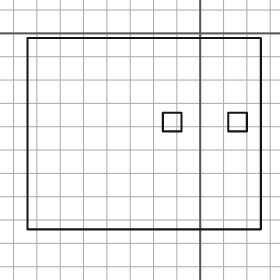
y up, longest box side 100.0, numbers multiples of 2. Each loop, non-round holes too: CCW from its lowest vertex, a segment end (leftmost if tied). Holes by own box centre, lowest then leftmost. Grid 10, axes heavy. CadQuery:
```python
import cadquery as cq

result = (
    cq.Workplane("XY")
    .moveTo(-74.0, -84.0)
    .lineTo(26.0, -84.0)
    .lineTo(26.0, -2.0)
    .lineTo(-74.0, -2.0)
    .close()
    .moveTo(-16.0, -42.0)
    .lineTo(-8.0, -42.0)
    .lineTo(-8.0, -34.0)
    .lineTo(-16.0, -34.0)
    .close()
    .moveTo(12.0, -42.0)
    .lineTo(20.0, -42.0)
    .lineTo(20.0, -34.0)
    .lineTo(12.0, -34.0)
    .close()
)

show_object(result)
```